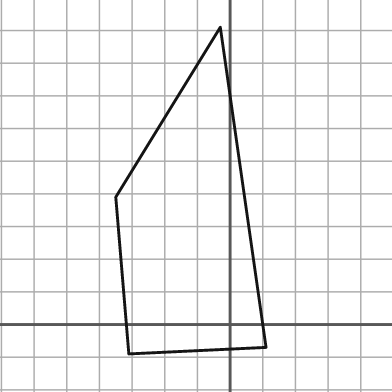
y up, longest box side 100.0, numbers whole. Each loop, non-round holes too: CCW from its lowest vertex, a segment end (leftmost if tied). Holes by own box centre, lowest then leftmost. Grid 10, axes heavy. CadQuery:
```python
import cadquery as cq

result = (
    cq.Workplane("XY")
    .moveTo(-31.0, -9.0)
    .lineTo(11.0, -7.0)
    .lineTo(-3.0, 91.0)
    .lineTo(-35.0, 39.0)
    .close()
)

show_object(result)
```